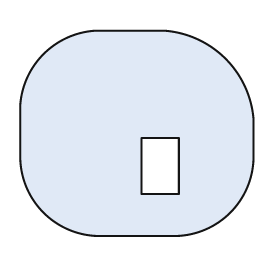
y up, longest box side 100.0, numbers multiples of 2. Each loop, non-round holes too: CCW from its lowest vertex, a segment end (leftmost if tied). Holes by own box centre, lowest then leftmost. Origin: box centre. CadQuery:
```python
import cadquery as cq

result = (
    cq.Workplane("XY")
    .moveTo(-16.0, -44.0)
    .lineTo(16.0, -44.0)
    .threePointArc((40.0, -34.0), (50.0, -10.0))
    .lineTo(50.0, 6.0)
    .threePointArc((38.0, 32.0), (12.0, 44.0))
    .lineTo(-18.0, 44.0)
    .threePointArc((-40.0, 34.0), (-50.0, 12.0))
    .lineTo(-50.0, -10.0)
    .threePointArc((-40.0, -34.0), (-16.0, -44.0))
    .close()
    .moveTo(2.0, -26.0)
    .lineTo(18.0, -26.0)
    .lineTo(18.0, -2.0)
    .lineTo(2.0, -2.0)
    .close()
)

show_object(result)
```